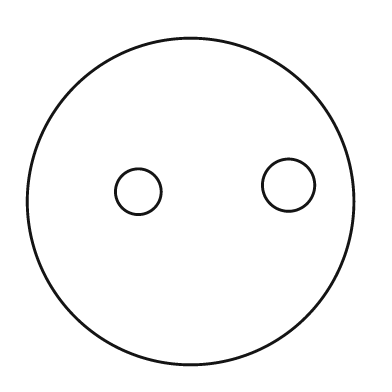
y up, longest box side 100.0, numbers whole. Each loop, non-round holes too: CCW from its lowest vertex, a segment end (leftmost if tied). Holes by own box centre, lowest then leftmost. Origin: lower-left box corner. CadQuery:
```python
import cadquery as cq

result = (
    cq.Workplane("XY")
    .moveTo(50.0, 50.0)
    .circle(50.0)
    .moveTo(34.0, 53.0)
    .circle(7.0)
    .moveTo(80.0, 55.0)
    .circle(8.0)
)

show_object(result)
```